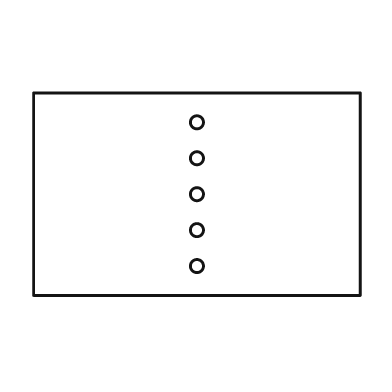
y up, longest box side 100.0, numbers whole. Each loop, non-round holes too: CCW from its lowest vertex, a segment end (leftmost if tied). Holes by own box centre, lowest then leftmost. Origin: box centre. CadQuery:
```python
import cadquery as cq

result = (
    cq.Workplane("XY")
    .moveTo(-50.0, -31.0)
    .lineTo(50.0, -31.0)
    .lineTo(50.0, 31.0)
    .lineTo(-50.0, 31.0)
    .close()
    .moveTo(0.0, -22.0)
    .circle(2.0)
    .moveTo(0.0, -11.0)
    .circle(2.0)
    .moveTo(0.0, 0.0)
    .circle(2.0)
    .moveTo(0.0, 11.0)
    .circle(2.0)
    .moveTo(0.0, 22.0)
    .circle(2.0)
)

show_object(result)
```